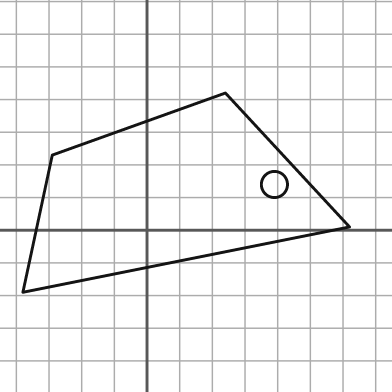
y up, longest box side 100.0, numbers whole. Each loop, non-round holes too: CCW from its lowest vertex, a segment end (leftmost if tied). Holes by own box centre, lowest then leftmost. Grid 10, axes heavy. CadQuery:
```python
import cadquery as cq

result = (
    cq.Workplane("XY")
    .moveTo(-38.0, -19.0)
    .lineTo(62.0, 1.0)
    .lineTo(24.0, 42.0)
    .lineTo(-29.0, 23.0)
    .close()
    .moveTo(39.0, 14.0)
    .circle(4.0)
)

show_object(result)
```